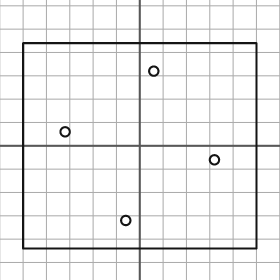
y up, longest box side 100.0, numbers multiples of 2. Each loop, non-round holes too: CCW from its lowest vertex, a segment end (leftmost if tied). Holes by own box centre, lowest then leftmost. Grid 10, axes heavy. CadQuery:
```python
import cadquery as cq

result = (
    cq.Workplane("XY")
    .moveTo(-50.0, -44.0)
    .lineTo(50.0, -44.0)
    .lineTo(50.0, 44.0)
    .lineTo(-50.0, 44.0)
    .close()
    .moveTo(-6.0, -32.0)
    .circle(2.0)
    .moveTo(32.0, -6.0)
    .circle(2.0)
    .moveTo(-32.0, 6.0)
    .circle(2.0)
    .moveTo(6.0, 32.0)
    .circle(2.0)
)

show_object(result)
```